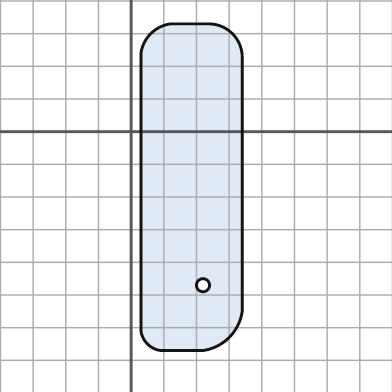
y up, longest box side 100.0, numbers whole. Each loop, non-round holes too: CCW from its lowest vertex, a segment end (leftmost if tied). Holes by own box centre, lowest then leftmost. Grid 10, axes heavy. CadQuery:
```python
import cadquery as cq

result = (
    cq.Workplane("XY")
    .moveTo(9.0, -67.0)
    .lineTo(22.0, -67.0)
    .threePointArc((30.0, -63.0), (34.0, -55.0))
    .lineTo(34.0, 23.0)
    .threePointArc((31.0, 30.0), (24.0, 33.0))
    .lineTo(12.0, 33.0)
    .threePointArc((6.0, 30.0), (3.0, 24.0))
    .lineTo(3.0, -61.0)
    .threePointArc((5.0, -65.0), (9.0, -67.0))
    .close()
    .moveTo(22.0, -47.0)
    .circle(2.0)
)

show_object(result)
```